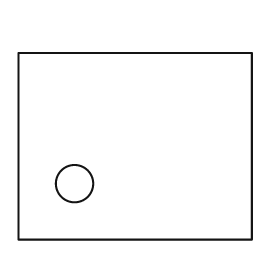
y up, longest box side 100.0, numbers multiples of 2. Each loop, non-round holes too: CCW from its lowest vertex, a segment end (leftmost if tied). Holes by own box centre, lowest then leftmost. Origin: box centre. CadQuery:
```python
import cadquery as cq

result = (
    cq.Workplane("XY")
    .moveTo(-50.0, -40.0)
    .lineTo(50.0, -40.0)
    .lineTo(50.0, 40.0)
    .lineTo(-50.0, 40.0)
    .close()
    .moveTo(-26.0, -16.0)
    .circle(8.0)
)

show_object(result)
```